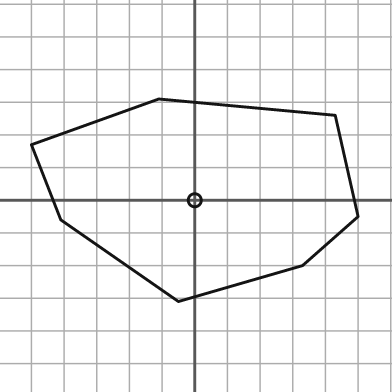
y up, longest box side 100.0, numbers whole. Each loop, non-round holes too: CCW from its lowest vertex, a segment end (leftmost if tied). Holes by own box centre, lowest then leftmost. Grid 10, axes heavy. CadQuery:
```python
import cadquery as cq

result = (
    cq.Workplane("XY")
    .moveTo(-5.0, -31.0)
    .lineTo(33.0, -20.0)
    .lineTo(50.0, -5.0)
    .lineTo(43.0, 26.0)
    .lineTo(-11.0, 31.0)
    .lineTo(-50.0, 17.0)
    .lineTo(-41.0, -6.0)
    .close()
    .moveTo(0.0, 0.0)
    .circle(2.0)
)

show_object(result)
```